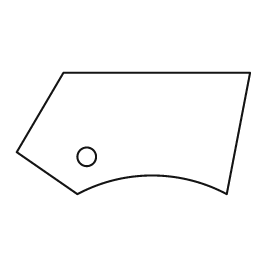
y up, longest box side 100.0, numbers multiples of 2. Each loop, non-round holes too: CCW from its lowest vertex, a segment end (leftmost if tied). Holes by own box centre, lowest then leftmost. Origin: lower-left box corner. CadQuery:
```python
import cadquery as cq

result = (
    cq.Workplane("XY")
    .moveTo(26.0, 0.0)
    .threePointArc((58.0, 8.0), (90.0, 0.0))
    .lineTo(100.0, 52.0)
    .lineTo(20.0, 52.0)
    .lineTo(0.0, 18.0)
    .close()
    .moveTo(30.0, 16.0)
    .circle(4.0)
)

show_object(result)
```